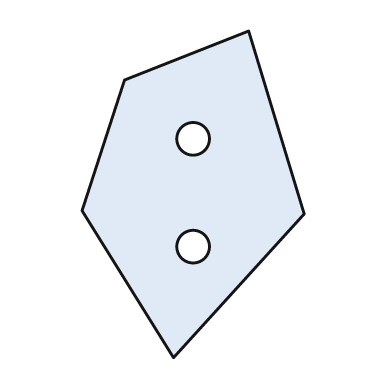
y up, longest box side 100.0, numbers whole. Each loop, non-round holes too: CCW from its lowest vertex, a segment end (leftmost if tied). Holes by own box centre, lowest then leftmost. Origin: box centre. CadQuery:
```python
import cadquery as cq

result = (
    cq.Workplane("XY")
    .moveTo(-6.0, -50.0)
    .lineTo(34.0, -6.0)
    .lineTo(17.0, 50.0)
    .lineTo(-21.0, 35.0)
    .lineTo(-34.0, -5.0)
    .close()
    .moveTo(0.0, -16.0)
    .circle(5.0)
    .moveTo(0.0, 17.0)
    .circle(5.0)
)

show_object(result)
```